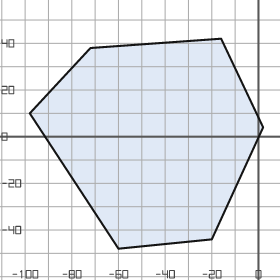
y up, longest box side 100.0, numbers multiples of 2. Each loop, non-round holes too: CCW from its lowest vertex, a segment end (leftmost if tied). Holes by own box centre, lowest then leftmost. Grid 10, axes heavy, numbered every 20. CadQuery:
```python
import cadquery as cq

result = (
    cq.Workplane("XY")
    .moveTo(-60.0, -48.0)
    .lineTo(-20.0, -44.0)
    .lineTo(2.0, 4.0)
    .lineTo(-16.0, 42.0)
    .lineTo(-72.0, 38.0)
    .lineTo(-98.0, 10.0)
    .close()
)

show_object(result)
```